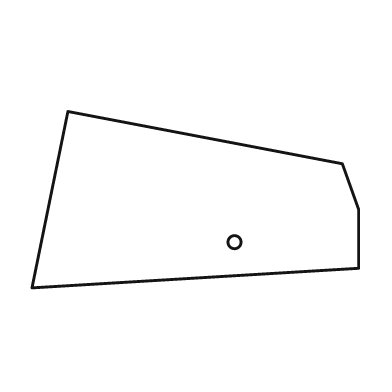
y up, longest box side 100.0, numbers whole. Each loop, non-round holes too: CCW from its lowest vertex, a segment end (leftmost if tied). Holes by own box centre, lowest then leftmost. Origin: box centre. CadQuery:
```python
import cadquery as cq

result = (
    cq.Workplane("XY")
    .moveTo(-50.0, -27.0)
    .lineTo(50.0, -21.0)
    .lineTo(50.0, -3.0)
    .lineTo(45.0, 11.0)
    .lineTo(-39.0, 27.0)
    .close()
    .moveTo(12.0, -13.0)
    .circle(2.0)
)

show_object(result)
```